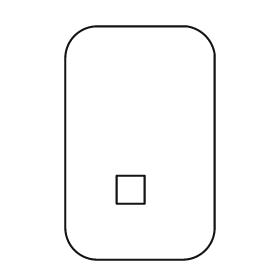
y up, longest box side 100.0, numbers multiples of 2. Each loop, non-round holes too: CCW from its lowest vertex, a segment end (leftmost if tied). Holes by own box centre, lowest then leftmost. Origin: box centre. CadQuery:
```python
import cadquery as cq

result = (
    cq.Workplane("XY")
    .moveTo(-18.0, -50.0)
    .lineTo(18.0, -50.0)
    .threePointArc((28.0, -46.0), (32.0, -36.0))
    .lineTo(32.0, 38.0)
    .threePointArc((28.0, 46.0), (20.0, 50.0))
    .lineTo(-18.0, 50.0)
    .threePointArc((-28.0, 46.0), (-32.0, 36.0))
    .lineTo(-32.0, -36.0)
    .threePointArc((-28.0, -46.0), (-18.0, -50.0))
    .close()
    .moveTo(-10.0, -26.0)
    .lineTo(2.0, -26.0)
    .lineTo(2.0, -14.0)
    .lineTo(-10.0, -14.0)
    .close()
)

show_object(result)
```